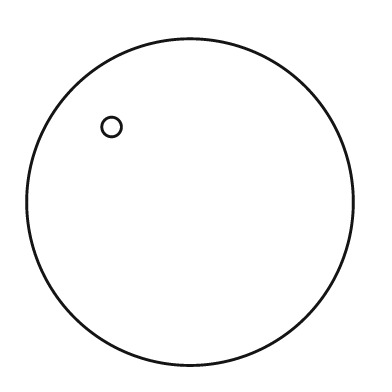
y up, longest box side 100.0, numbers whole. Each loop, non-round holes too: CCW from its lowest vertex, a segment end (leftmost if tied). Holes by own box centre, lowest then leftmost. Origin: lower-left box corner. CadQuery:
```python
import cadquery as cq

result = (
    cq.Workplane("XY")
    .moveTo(50.0, 50.0)
    .circle(50.0)
    .moveTo(26.0, 73.0)
    .circle(3.0)
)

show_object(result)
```